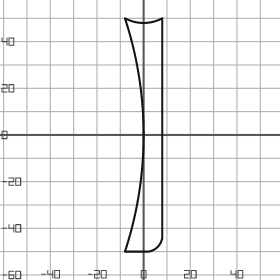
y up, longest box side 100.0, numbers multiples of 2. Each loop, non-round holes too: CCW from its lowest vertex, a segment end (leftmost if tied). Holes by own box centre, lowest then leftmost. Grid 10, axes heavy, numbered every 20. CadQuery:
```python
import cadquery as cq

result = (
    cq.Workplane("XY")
    .moveTo(-8.0, -50.0)
    .lineTo(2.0, -50.0)
    .threePointArc((6.0, -48.0), (8.0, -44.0))
    .lineTo(8.0, 50.0)
    .threePointArc((0.0, 48.0), (-8.0, 50.0))
    .threePointArc((0.0, 0.0), (-8.0, -50.0))
    .close()
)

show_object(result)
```